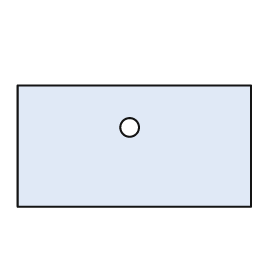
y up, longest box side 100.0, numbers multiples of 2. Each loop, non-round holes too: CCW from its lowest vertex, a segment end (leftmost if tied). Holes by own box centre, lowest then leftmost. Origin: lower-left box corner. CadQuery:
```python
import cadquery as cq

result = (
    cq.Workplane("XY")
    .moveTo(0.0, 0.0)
    .lineTo(100.0, 0.0)
    .lineTo(100.0, 52.0)
    .lineTo(0.0, 52.0)
    .close()
    .moveTo(48.0, 34.0)
    .circle(4.0)
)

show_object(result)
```